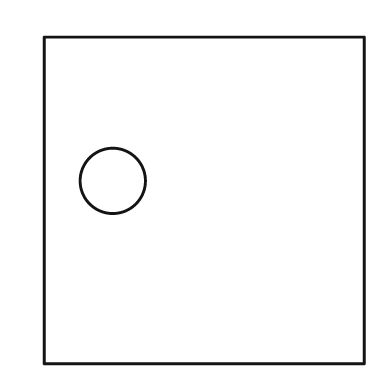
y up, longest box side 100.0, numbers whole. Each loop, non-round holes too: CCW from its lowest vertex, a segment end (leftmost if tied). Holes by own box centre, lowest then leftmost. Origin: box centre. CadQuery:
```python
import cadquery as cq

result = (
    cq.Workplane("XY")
    .moveTo(-49.0, -50.0)
    .lineTo(49.0, -50.0)
    .lineTo(49.0, 50.0)
    .lineTo(-49.0, 50.0)
    .close()
    .moveTo(-28.0, 6.0)
    .circle(10.0)
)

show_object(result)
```